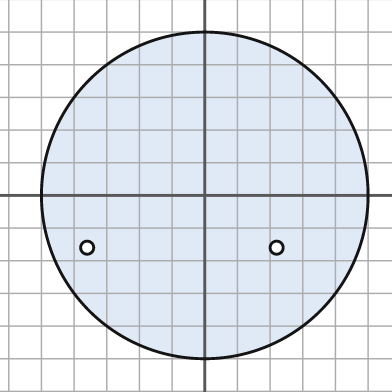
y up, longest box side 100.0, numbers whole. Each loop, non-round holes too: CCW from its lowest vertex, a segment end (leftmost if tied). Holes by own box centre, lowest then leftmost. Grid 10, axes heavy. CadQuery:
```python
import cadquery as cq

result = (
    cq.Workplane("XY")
    .moveTo(0.0, 0.0)
    .circle(50.0)
    .moveTo(-36.0, -16.0)
    .circle(2.0)
    .moveTo(22.0, -16.0)
    .circle(2.0)
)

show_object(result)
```